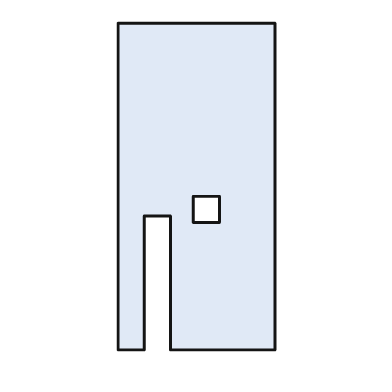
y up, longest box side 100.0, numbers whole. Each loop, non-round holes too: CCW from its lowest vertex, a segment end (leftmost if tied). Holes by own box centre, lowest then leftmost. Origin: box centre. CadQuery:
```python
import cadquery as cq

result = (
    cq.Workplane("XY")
    .moveTo(-24.0, -50.0)
    .lineTo(-16.0, -50.0)
    .lineTo(-16.0, -9.0)
    .lineTo(-8.0, -9.0)
    .lineTo(-8.0, -50.0)
    .lineTo(24.0, -50.0)
    .lineTo(24.0, 50.0)
    .lineTo(-24.0, 50.0)
    .close()
    .moveTo(-1.0, -11.0)
    .lineTo(7.0, -11.0)
    .lineTo(7.0, -3.0)
    .lineTo(-1.0, -3.0)
    .close()
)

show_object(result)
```